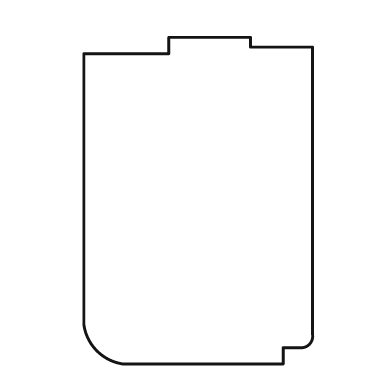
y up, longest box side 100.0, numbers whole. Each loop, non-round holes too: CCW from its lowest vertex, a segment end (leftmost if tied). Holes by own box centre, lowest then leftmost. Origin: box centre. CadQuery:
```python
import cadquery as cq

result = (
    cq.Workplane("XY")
    .moveTo(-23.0, -50.0)
    .lineTo(26.0, -50.0)
    .lineTo(26.0, -45.0)
    .lineTo(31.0, -45.0)
    .threePointArc((34.0, -44.0), (35.0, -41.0))
    .lineTo(35.0, 47.0)
    .lineTo(16.0, 47.0)
    .lineTo(16.0, 50.0)
    .lineTo(-9.0, 50.0)
    .lineTo(-9.0, 45.0)
    .lineTo(-35.0, 45.0)
    .lineTo(-35.0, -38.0)
    .threePointArc((-31.0, -46.0), (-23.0, -50.0))
    .close()
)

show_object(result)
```